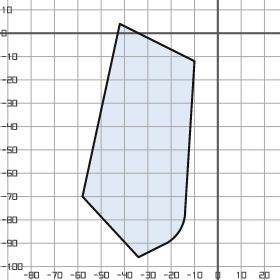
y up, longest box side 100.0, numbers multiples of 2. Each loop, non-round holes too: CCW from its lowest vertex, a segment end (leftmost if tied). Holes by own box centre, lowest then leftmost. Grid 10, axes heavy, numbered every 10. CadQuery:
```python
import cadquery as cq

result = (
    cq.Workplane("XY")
    .moveTo(-34.0, -96.0)
    .lineTo(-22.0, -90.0)
    .threePointArc((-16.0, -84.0), (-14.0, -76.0))
    .lineTo(-10.0, -12.0)
    .lineTo(-42.0, 4.0)
    .lineTo(-58.0, -70.0)
    .close()
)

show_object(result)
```